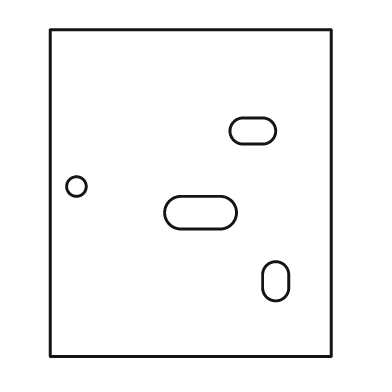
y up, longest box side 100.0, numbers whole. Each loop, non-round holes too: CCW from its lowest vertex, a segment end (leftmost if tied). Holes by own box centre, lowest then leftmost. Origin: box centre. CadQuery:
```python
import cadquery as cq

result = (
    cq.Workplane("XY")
    .moveTo(-43.0, -50.0)
    .lineTo(43.0, -50.0)
    .lineTo(43.0, 50.0)
    .lineTo(-43.0, 50.0)
    .close()
    .moveTo(22.0, -29.0)
    .threePointArc((26.0, -33.0), (30.0, -29.0))
    .lineTo(30.0, -25.0)
    .threePointArc((26.0, -21.0), (22.0, -25.0))
    .close()
    .moveTo(-3.0, -11.0)
    .lineTo(9.0, -11.0)
    .threePointArc((14.0, -6.0), (9.0, -1.0))
    .lineTo(-3.0, -1.0)
    .threePointArc((-8.0, -6.0), (-3.0, -11.0))
    .close()
    .moveTo(-35.0, 2.0)
    .circle(3.0)
    .moveTo(16.0, 15.0)
    .lineTo(22.0, 15.0)
    .threePointArc((26.0, 19.0), (22.0, 23.0))
    .lineTo(16.0, 23.0)
    .threePointArc((12.0, 19.0), (16.0, 15.0))
    .close()
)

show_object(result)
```